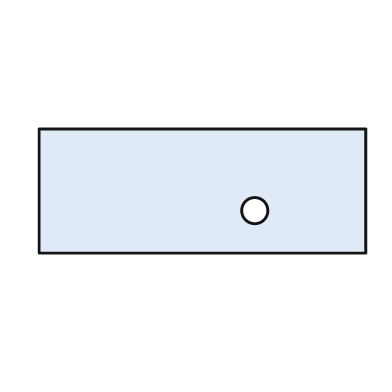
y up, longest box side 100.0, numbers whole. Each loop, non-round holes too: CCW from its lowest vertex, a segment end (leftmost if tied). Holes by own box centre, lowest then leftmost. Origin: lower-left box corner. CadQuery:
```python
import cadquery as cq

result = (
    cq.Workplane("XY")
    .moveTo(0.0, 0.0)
    .lineTo(100.0, 0.0)
    .lineTo(100.0, 38.0)
    .lineTo(0.0, 38.0)
    .close()
    .moveTo(66.0, 13.0)
    .circle(4.0)
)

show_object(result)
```